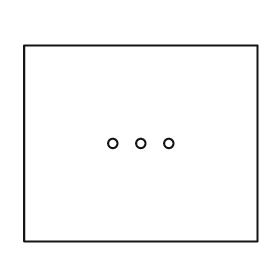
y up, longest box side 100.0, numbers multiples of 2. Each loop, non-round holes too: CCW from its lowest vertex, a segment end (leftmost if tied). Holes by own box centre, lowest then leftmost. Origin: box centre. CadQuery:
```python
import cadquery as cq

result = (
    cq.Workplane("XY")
    .moveTo(-50.0, -42.0)
    .lineTo(50.0, -42.0)
    .lineTo(50.0, 42.0)
    .lineTo(-50.0, 42.0)
    .close()
    .moveTo(-12.0, 0.0)
    .circle(2.0)
    .moveTo(0.0, 0.0)
    .circle(2.0)
    .moveTo(12.0, 0.0)
    .circle(2.0)
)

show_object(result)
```